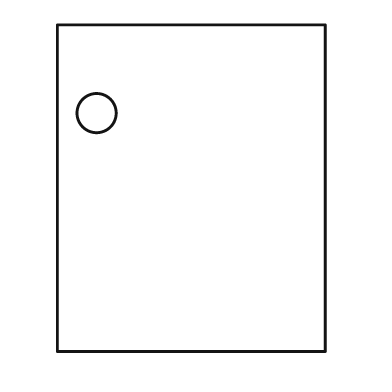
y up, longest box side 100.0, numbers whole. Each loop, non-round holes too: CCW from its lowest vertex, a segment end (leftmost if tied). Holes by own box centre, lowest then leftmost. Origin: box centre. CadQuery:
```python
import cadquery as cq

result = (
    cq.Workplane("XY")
    .moveTo(-41.0, -50.0)
    .lineTo(41.0, -50.0)
    .lineTo(41.0, 50.0)
    .lineTo(-41.0, 50.0)
    .close()
    .moveTo(-29.0, 23.0)
    .circle(6.0)
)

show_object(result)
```